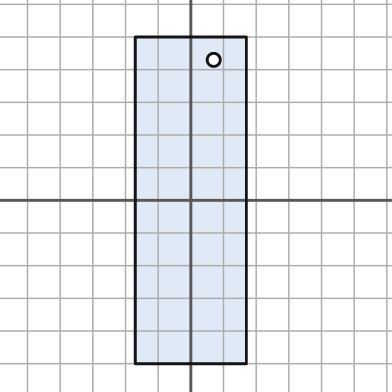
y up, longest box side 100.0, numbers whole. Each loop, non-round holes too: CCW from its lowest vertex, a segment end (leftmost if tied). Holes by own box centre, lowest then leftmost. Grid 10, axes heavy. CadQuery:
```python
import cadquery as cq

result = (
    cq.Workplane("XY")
    .moveTo(-17.0, -50.0)
    .lineTo(17.0, -50.0)
    .lineTo(17.0, 50.0)
    .lineTo(-17.0, 50.0)
    .close()
    .moveTo(7.0, 43.0)
    .circle(2.0)
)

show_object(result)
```